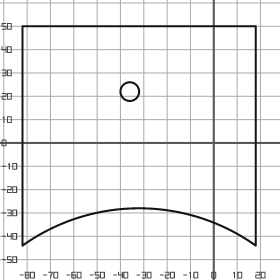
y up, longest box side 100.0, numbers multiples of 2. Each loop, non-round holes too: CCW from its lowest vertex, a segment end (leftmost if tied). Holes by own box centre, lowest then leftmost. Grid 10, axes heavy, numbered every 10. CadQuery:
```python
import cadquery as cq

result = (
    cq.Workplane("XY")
    .moveTo(-82.0, -44.0)
    .threePointArc((-32.0, -28.0), (18.0, -44.0))
    .lineTo(18.0, 50.0)
    .lineTo(-82.0, 50.0)
    .close()
    .moveTo(-36.0, 22.0)
    .circle(4.0)
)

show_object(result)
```